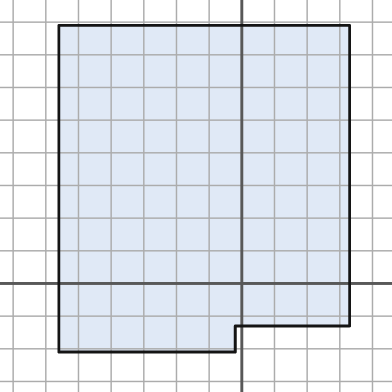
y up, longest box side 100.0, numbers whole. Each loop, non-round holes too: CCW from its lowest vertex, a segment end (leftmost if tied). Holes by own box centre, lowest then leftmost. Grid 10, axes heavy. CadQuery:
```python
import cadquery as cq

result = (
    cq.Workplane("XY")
    .moveTo(-56.0, -21.0)
    .lineTo(-2.0, -21.0)
    .lineTo(-2.0, -13.0)
    .lineTo(33.0, -13.0)
    .lineTo(33.0, 79.0)
    .lineTo(-56.0, 79.0)
    .close()
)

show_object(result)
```